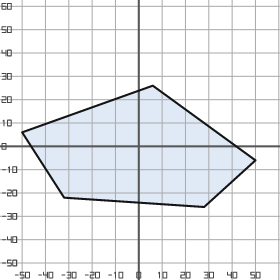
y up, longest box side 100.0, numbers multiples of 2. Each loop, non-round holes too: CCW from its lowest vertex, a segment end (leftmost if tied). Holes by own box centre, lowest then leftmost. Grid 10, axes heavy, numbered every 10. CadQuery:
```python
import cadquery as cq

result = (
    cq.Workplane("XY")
    .moveTo(28.0, -26.0)
    .lineTo(50.0, -6.0)
    .lineTo(6.0, 26.0)
    .lineTo(-50.0, 6.0)
    .lineTo(-32.0, -22.0)
    .close()
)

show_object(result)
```